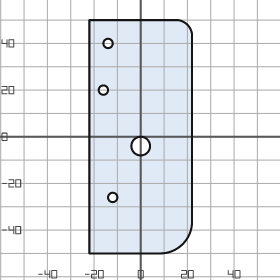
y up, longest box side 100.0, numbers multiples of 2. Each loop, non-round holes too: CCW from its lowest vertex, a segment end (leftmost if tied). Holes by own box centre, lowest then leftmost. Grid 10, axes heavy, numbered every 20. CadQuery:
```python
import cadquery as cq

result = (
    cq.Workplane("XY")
    .moveTo(-22.0, -50.0)
    .lineTo(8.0, -50.0)
    .threePointArc((18.0, -46.0), (22.0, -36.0))
    .lineTo(22.0, 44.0)
    .threePointArc((20.0, 48.0), (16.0, 50.0))
    .lineTo(-22.0, 50.0)
    .close()
    .moveTo(-12.0, -26.0)
    .circle(2.0)
    .moveTo(0.0, -4.0)
    .circle(4.0)
    .moveTo(-16.0, 20.0)
    .circle(2.0)
    .moveTo(-14.0, 40.0)
    .circle(2.0)
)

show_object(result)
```